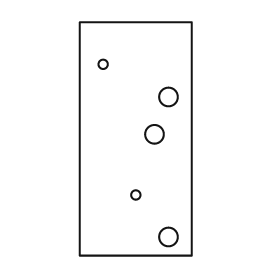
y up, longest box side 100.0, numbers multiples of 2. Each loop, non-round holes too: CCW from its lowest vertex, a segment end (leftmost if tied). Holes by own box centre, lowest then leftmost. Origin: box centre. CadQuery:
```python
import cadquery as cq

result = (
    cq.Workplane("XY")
    .moveTo(-24.0, -50.0)
    .lineTo(24.0, -50.0)
    .lineTo(24.0, 50.0)
    .lineTo(-24.0, 50.0)
    .close()
    .moveTo(14.0, -42.0)
    .circle(4.0)
    .moveTo(0.0, -24.0)
    .circle(2.0)
    .moveTo(8.0, 2.0)
    .circle(4.0)
    .moveTo(14.0, 18.0)
    .circle(4.0)
    .moveTo(-14.0, 32.0)
    .circle(2.0)
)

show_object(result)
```